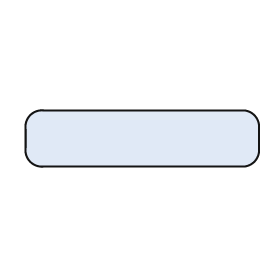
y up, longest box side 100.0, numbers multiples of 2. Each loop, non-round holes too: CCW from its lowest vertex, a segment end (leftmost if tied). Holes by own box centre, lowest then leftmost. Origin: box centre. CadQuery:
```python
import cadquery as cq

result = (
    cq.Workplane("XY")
    .moveTo(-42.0, -12.0)
    .lineTo(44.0, -12.0)
    .threePointArc((48.0, -10.0), (50.0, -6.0))
    .lineTo(50.0, 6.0)
    .threePointArc((48.0, 10.0), (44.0, 12.0))
    .lineTo(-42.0, 12.0)
    .threePointArc((-48.0, 10.0), (-50.0, 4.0))
    .lineTo(-50.0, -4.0)
    .threePointArc((-48.0, -10.0), (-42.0, -12.0))
    .close()
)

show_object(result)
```